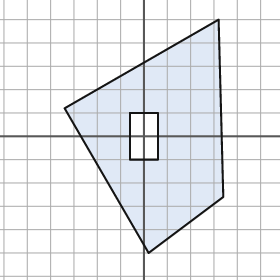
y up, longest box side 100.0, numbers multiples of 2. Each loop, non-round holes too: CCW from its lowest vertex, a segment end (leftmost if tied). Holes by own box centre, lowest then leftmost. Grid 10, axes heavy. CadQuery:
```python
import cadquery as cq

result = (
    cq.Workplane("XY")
    .moveTo(2.0, -50.0)
    .lineTo(34.0, -26.0)
    .lineTo(32.0, 50.0)
    .lineTo(-34.0, 12.0)
    .close()
    .moveTo(-6.0, -10.0)
    .lineTo(6.0, -10.0)
    .lineTo(6.0, 10.0)
    .lineTo(-6.0, 10.0)
    .close()
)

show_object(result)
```